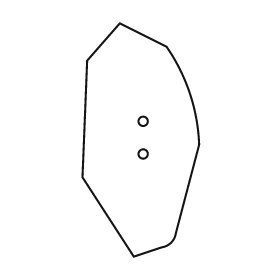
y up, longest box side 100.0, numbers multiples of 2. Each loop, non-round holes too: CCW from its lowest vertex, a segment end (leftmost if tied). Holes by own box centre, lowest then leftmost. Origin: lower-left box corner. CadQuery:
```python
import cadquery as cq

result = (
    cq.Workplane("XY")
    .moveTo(22.0, 0.0)
    .lineTo(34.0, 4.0)
    .threePointArc((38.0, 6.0), (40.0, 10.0))
    .lineTo(50.0, 48.0)
    .threePointArc((46.0, 70.0), (36.0, 90.0))
    .lineTo(16.0, 100.0)
    .lineTo(2.0, 84.0)
    .lineTo(0.0, 34.0)
    .close()
    .moveTo(26.0, 44.0)
    .circle(2.0)
    .moveTo(26.0, 58.0)
    .circle(2.0)
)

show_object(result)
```